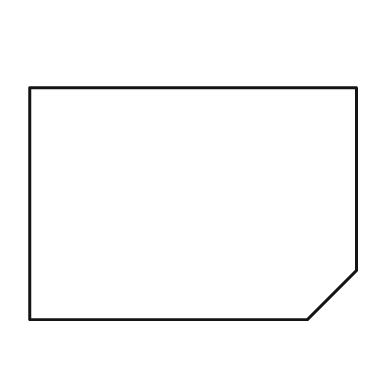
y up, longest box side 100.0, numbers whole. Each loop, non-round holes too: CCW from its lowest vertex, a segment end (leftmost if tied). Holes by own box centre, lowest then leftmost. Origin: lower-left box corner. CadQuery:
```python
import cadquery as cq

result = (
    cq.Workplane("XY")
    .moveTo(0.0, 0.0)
    .lineTo(85.0, 0.0)
    .lineTo(100.0, 15.0)
    .lineTo(100.0, 71.0)
    .lineTo(0.0, 71.0)
    .close()
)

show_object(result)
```